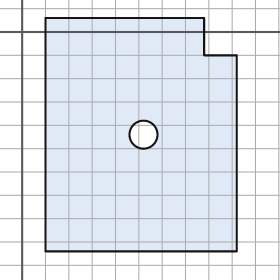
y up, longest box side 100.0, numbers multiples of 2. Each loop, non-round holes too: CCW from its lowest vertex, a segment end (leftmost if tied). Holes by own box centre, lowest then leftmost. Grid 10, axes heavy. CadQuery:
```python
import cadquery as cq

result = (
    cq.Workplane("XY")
    .moveTo(10.0, -94.0)
    .lineTo(92.0, -94.0)
    .lineTo(92.0, -10.0)
    .lineTo(78.0, -10.0)
    .lineTo(78.0, 6.0)
    .lineTo(10.0, 6.0)
    .close()
    .moveTo(52.0, -44.0)
    .circle(6.0)
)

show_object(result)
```